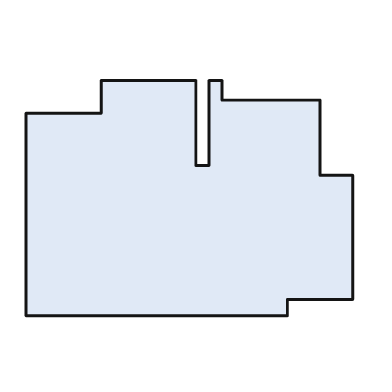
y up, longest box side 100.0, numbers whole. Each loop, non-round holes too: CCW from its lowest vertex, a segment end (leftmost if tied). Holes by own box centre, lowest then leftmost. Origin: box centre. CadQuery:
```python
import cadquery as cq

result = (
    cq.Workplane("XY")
    .moveTo(-50.0, -36.0)
    .lineTo(30.0, -36.0)
    .lineTo(30.0, -31.0)
    .lineTo(50.0, -31.0)
    .lineTo(50.0, 7.0)
    .lineTo(40.0, 7.0)
    .lineTo(40.0, 30.0)
    .lineTo(10.0, 30.0)
    .lineTo(10.0, 36.0)
    .lineTo(6.0, 36.0)
    .lineTo(6.0, 10.0)
    .lineTo(2.0, 10.0)
    .lineTo(2.0, 36.0)
    .lineTo(-27.0, 36.0)
    .lineTo(-27.0, 26.0)
    .lineTo(-50.0, 26.0)
    .close()
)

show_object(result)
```